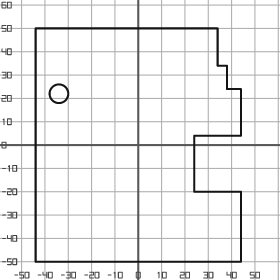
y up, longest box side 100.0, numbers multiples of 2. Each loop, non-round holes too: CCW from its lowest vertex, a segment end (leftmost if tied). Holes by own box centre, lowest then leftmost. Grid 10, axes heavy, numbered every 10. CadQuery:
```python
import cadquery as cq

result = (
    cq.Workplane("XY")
    .moveTo(-44.0, -50.0)
    .lineTo(44.0, -50.0)
    .lineTo(44.0, -20.0)
    .lineTo(24.0, -20.0)
    .lineTo(24.0, 4.0)
    .lineTo(44.0, 4.0)
    .lineTo(44.0, 24.0)
    .lineTo(38.0, 24.0)
    .lineTo(38.0, 34.0)
    .lineTo(34.0, 34.0)
    .lineTo(34.0, 50.0)
    .lineTo(-44.0, 50.0)
    .close()
    .moveTo(-34.0, 22.0)
    .circle(4.0)
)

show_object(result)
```